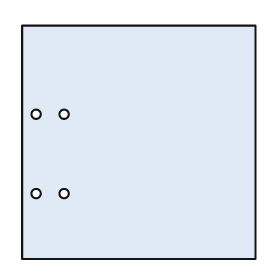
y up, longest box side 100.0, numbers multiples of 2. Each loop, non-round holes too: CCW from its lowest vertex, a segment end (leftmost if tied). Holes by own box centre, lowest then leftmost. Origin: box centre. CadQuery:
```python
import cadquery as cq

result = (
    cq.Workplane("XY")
    .moveTo(-50.0, -50.0)
    .lineTo(50.0, -50.0)
    .lineTo(50.0, 50.0)
    .lineTo(-50.0, 50.0)
    .close()
    .moveTo(-44.0, -22.0)
    .circle(2.0)
    .moveTo(-32.0, -22.0)
    .circle(2.0)
    .moveTo(-44.0, 12.0)
    .circle(2.0)
    .moveTo(-32.0, 12.0)
    .circle(2.0)
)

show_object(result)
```